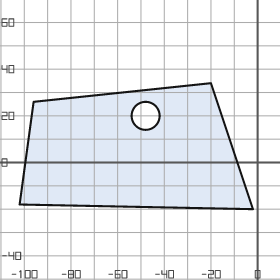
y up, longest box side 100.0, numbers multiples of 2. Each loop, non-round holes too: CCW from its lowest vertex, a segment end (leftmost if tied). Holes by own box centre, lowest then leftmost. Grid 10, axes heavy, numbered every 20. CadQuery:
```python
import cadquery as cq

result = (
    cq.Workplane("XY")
    .moveTo(-2.0, -20.0)
    .lineTo(-20.0, 34.0)
    .lineTo(-96.0, 26.0)
    .lineTo(-102.0, -18.0)
    .close()
    .moveTo(-48.0, 20.0)
    .circle(6.0)
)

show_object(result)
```